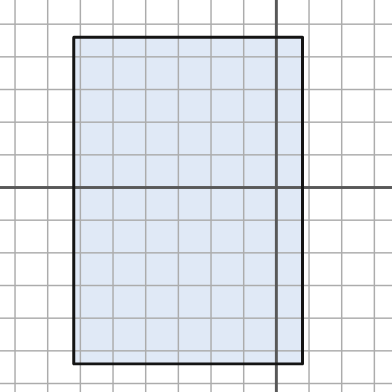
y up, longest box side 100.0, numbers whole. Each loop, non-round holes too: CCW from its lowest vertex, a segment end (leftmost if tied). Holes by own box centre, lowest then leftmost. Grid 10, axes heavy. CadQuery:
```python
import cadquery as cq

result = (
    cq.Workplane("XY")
    .moveTo(-62.0, -54.0)
    .lineTo(8.0, -54.0)
    .lineTo(8.0, 46.0)
    .lineTo(-62.0, 46.0)
    .close()
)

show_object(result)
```